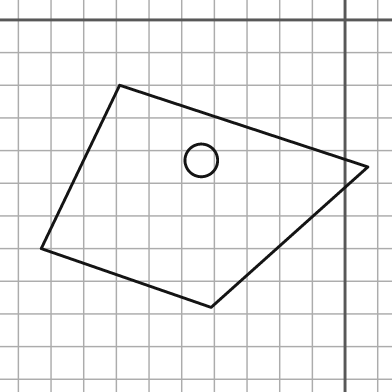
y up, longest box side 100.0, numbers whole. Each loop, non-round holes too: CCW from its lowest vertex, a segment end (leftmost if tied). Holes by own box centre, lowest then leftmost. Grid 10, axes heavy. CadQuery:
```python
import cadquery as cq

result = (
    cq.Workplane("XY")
    .moveTo(-41.0, -88.0)
    .lineTo(7.0, -45.0)
    .lineTo(-69.0, -20.0)
    .lineTo(-93.0, -70.0)
    .close()
    .moveTo(-44.0, -43.0)
    .circle(5.0)
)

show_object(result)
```